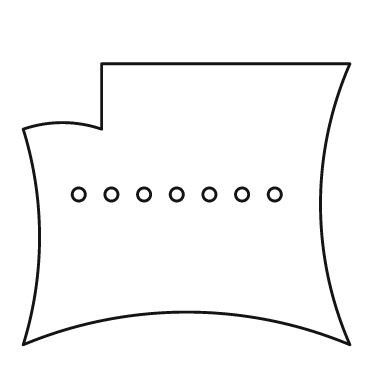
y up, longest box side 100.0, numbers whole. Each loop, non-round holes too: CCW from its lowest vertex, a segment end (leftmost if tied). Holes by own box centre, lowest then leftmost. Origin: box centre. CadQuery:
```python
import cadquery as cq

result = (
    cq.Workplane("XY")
    .moveTo(-50.0, -43.0)
    .threePointArc((0.0, -33.0), (50.0, -43.0))
    .threePointArc((41.0, 0.0), (50.0, 43.0))
    .lineTo(-26.0, 43.0)
    .lineTo(-26.0, 23.0)
    .threePointArc((-38.0, 25.0), (-50.0, 23.0))
    .threePointArc((-45.0, -10.0), (-50.0, -43.0))
    .close()
    .moveTo(-33.0, 3.0)
    .circle(2.0)
    .moveTo(-23.0, 3.0)
    .circle(2.0)
    .moveTo(-13.0, 3.0)
    .circle(2.0)
    .moveTo(-3.0, 3.0)
    .circle(2.0)
    .moveTo(7.0, 3.0)
    .circle(2.0)
    .moveTo(17.0, 3.0)
    .circle(2.0)
    .moveTo(27.0, 3.0)
    .circle(2.0)
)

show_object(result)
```